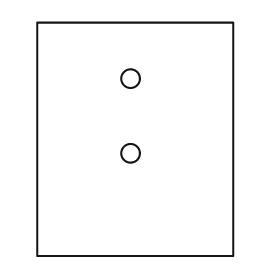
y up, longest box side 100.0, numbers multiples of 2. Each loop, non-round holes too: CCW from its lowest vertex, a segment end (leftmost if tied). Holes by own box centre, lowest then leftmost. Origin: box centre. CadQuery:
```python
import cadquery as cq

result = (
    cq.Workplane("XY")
    .moveTo(-42.0, -50.0)
    .lineTo(42.0, -50.0)
    .lineTo(42.0, 50.0)
    .lineTo(-42.0, 50.0)
    .close()
    .moveTo(-2.0, -6.0)
    .circle(4.0)
    .moveTo(-2.0, 26.0)
    .circle(4.0)
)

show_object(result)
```